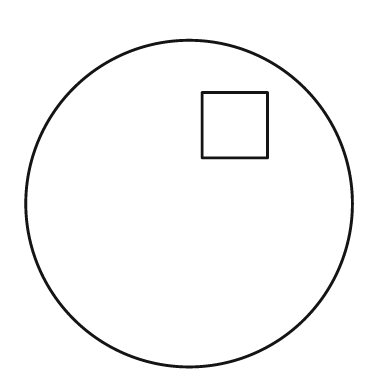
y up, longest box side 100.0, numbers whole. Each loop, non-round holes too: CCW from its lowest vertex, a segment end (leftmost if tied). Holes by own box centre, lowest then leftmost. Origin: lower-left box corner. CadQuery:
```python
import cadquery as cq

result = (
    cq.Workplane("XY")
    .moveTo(50.0, 50.0)
    .circle(50.0)
    .moveTo(54.0, 64.0)
    .lineTo(74.0, 64.0)
    .lineTo(74.0, 84.0)
    .lineTo(54.0, 84.0)
    .close()
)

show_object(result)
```